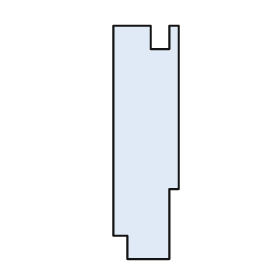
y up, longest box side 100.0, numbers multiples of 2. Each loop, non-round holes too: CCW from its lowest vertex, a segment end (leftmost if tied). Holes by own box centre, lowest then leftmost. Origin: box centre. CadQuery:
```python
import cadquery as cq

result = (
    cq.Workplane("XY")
    .moveTo(-8.0, -50.0)
    .lineTo(10.0, -50.0)
    .lineTo(10.0, -20.0)
    .lineTo(14.0, -20.0)
    .lineTo(14.0, 50.0)
    .lineTo(10.0, 50.0)
    .lineTo(10.0, 40.0)
    .lineTo(2.0, 40.0)
    .lineTo(2.0, 50.0)
    .lineTo(-14.0, 50.0)
    .lineTo(-14.0, -40.0)
    .lineTo(-8.0, -40.0)
    .close()
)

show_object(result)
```